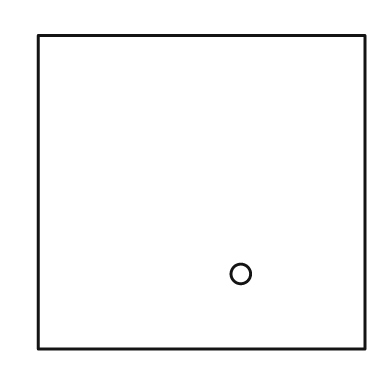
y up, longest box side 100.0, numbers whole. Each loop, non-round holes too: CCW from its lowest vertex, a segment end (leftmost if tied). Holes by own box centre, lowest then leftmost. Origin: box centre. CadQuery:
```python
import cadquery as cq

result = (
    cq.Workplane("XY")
    .moveTo(-50.0, -48.0)
    .lineTo(50.0, -48.0)
    .lineTo(50.0, 48.0)
    .lineTo(-50.0, 48.0)
    .close()
    .moveTo(12.0, -25.0)
    .circle(3.0)
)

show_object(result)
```